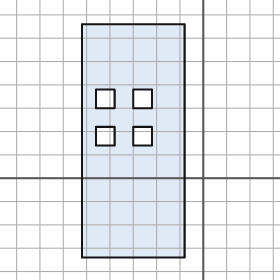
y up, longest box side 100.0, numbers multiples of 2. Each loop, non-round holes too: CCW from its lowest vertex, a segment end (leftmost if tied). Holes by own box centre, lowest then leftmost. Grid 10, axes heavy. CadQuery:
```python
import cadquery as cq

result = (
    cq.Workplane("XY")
    .moveTo(-52.0, -34.0)
    .lineTo(-8.0, -34.0)
    .lineTo(-8.0, 66.0)
    .lineTo(-52.0, 66.0)
    .close()
    .moveTo(-46.0, 14.0)
    .lineTo(-38.0, 14.0)
    .lineTo(-38.0, 22.0)
    .lineTo(-46.0, 22.0)
    .close()
    .moveTo(-30.0, 14.0)
    .lineTo(-22.0, 14.0)
    .lineTo(-22.0, 22.0)
    .lineTo(-30.0, 22.0)
    .close()
    .moveTo(-46.0, 30.0)
    .lineTo(-38.0, 30.0)
    .lineTo(-38.0, 38.0)
    .lineTo(-46.0, 38.0)
    .close()
    .moveTo(-30.0, 30.0)
    .lineTo(-22.0, 30.0)
    .lineTo(-22.0, 38.0)
    .lineTo(-30.0, 38.0)
    .close()
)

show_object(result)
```